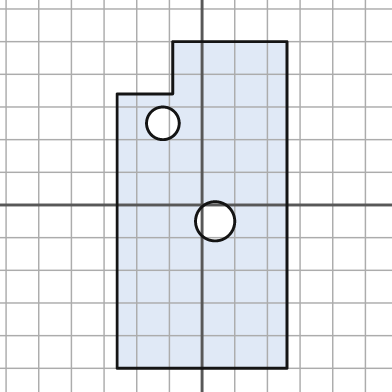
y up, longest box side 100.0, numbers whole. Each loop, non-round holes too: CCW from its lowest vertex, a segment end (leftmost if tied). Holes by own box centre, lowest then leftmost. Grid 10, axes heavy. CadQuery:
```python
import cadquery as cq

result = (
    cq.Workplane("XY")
    .moveTo(-26.0, -50.0)
    .lineTo(26.0, -50.0)
    .lineTo(26.0, 50.0)
    .lineTo(-9.0, 50.0)
    .lineTo(-9.0, 34.0)
    .lineTo(-26.0, 34.0)
    .close()
    .moveTo(4.0, -5.0)
    .circle(6.0)
    .moveTo(-12.0, 25.0)
    .circle(5.0)
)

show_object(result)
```